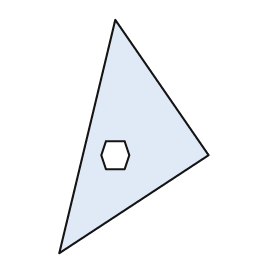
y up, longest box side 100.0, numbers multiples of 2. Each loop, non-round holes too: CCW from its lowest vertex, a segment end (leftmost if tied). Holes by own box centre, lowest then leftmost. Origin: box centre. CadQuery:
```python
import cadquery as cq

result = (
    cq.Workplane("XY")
    .moveTo(-32.0, -50.0)
    .lineTo(32.0, -8.0)
    .lineTo(-8.0, 50.0)
    .close()
    .moveTo(-12.0, -14.0)
    .lineTo(-4.0, -14.0)
    .lineTo(-2.0, -8.0)
    .lineTo(-4.0, -2.0)
    .lineTo(-12.0, -2.0)
    .lineTo(-14.0, -8.0)
    .close()
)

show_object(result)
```